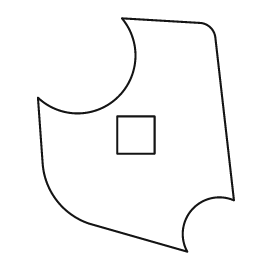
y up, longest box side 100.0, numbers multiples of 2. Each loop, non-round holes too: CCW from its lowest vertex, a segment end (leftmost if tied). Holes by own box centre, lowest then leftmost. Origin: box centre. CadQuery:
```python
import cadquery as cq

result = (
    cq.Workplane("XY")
    .moveTo(22.0, -50.0)
    .threePointArc((24.0, -32.0), (42.0, -28.0))
    .lineTo(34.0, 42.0)
    .threePointArc((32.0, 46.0), (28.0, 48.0))
    .lineTo(-6.0, 50.0)
    .threePointArc((-8.0, 16.0), (-42.0, 16.0))
    .lineTo(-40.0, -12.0)
    .threePointArc((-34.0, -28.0), (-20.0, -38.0))
    .close()
    .moveTo(-8.0, -8.0)
    .lineTo(8.0, -8.0)
    .lineTo(8.0, 8.0)
    .lineTo(-8.0, 8.0)
    .close()
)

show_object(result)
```